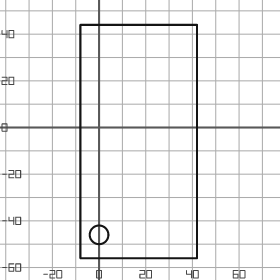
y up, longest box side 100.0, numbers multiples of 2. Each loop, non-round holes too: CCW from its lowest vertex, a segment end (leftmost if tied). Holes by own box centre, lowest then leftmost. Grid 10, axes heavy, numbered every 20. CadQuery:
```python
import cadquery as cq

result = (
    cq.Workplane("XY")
    .moveTo(-8.0, -56.0)
    .lineTo(42.0, -56.0)
    .lineTo(42.0, 44.0)
    .lineTo(-8.0, 44.0)
    .close()
    .moveTo(0.0, -46.0)
    .circle(4.0)
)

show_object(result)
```